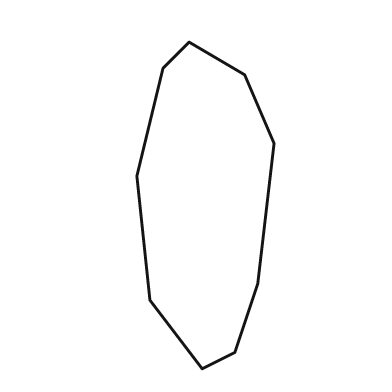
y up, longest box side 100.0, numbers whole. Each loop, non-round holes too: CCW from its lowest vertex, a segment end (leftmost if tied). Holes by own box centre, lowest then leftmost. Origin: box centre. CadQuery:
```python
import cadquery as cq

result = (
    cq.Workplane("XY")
    .moveTo(-1.0, -50.0)
    .lineTo(9.0, -45.0)
    .lineTo(16.0, -24.0)
    .lineTo(21.0, 19.0)
    .lineTo(12.0, 40.0)
    .lineTo(-5.0, 50.0)
    .lineTo(-13.0, 42.0)
    .lineTo(-21.0, 9.0)
    .lineTo(-17.0, -29.0)
    .close()
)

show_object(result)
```